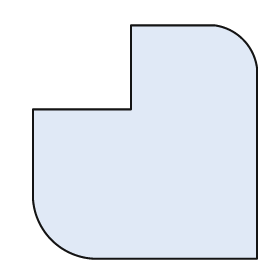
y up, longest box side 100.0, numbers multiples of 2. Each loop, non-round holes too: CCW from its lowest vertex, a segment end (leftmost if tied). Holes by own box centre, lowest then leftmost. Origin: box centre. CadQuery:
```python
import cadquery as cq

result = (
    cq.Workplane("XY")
    .moveTo(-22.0, -50.0)
    .lineTo(48.0, -50.0)
    .lineTo(48.0, 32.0)
    .threePointArc((42.0, 44.0), (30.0, 50.0))
    .lineTo(-6.0, 50.0)
    .lineTo(-6.0, 14.0)
    .lineTo(-48.0, 14.0)
    .lineTo(-48.0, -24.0)
    .threePointArc((-40.0, -42.0), (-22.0, -50.0))
    .close()
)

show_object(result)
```